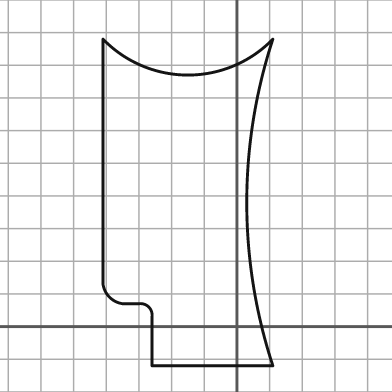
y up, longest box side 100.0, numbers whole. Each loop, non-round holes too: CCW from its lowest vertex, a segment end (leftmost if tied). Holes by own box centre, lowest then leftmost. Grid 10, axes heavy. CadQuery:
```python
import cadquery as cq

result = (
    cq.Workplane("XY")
    .moveTo(-26.0, -12.0)
    .lineTo(11.0, -12.0)
    .threePointArc((3.0, 38.0), (11.0, 88.0))
    .threePointArc((-15.0, 77.0), (-41.0, 88.0))
    .lineTo(-41.0, 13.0)
    .threePointArc((-39.0, 9.0), (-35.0, 7.0))
    .lineTo(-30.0, 7.0)
    .threePointArc((-27.0, 6.0), (-26.0, 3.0))
    .close()
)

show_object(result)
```